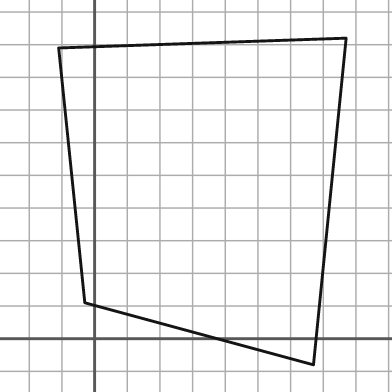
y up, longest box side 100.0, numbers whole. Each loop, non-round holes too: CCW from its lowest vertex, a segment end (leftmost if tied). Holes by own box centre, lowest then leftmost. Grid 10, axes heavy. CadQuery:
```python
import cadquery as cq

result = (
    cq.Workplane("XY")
    .moveTo(67.0, -8.0)
    .lineTo(77.0, 92.0)
    .lineTo(-11.0, 89.0)
    .lineTo(-3.0, 11.0)
    .close()
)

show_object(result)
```